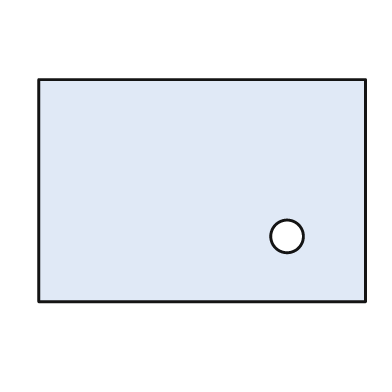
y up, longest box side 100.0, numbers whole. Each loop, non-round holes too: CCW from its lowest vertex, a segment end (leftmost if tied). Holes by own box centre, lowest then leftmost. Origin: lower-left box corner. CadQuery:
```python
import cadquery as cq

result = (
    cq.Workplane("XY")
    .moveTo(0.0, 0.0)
    .lineTo(100.0, 0.0)
    .lineTo(100.0, 68.0)
    .lineTo(0.0, 68.0)
    .close()
    .moveTo(76.0, 20.0)
    .circle(5.0)
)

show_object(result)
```